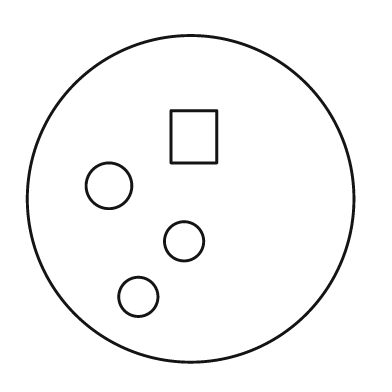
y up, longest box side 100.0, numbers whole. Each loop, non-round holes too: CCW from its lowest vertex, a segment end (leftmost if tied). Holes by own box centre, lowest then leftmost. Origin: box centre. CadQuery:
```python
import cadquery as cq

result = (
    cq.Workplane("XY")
    .moveTo(0.0, 0.0)
    .circle(50.0)
    .moveTo(-16.0, -30.0)
    .circle(6.0)
    .moveTo(-2.0, -13.0)
    .circle(6.0)
    .moveTo(-25.0, 4.0)
    .circle(7.0)
    .moveTo(-6.0, 11.0)
    .lineTo(8.0, 11.0)
    .lineTo(8.0, 27.0)
    .lineTo(-6.0, 27.0)
    .close()
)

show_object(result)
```